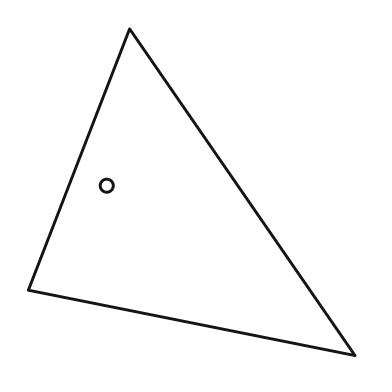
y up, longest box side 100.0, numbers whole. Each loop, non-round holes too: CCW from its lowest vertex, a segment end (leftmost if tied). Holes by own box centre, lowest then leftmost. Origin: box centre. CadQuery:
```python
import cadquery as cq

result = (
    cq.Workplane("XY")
    .moveTo(50.0, -50.0)
    .lineTo(-19.0, 50.0)
    .lineTo(-50.0, -30.0)
    .close()
    .moveTo(-26.0, 2.0)
    .circle(2.0)
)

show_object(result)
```